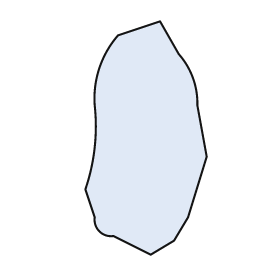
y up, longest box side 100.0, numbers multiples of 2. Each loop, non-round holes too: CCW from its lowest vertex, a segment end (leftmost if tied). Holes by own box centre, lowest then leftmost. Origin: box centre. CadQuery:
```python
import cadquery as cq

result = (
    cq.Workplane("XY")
    .moveTo(2.0, -50.0)
    .lineTo(12.0, -44.0)
    .lineTo(18.0, -34.0)
    .lineTo(26.0, -8.0)
    .lineTo(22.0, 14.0)
    .threePointArc((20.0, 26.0), (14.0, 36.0))
    .lineTo(6.0, 50.0)
    .lineTo(-12.0, 44.0)
    .threePointArc((-20.0, 30.0), (-22.0, 14.0))
    .threePointArc((-22.0, -4.0), (-26.0, -22.0))
    .lineTo(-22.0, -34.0)
    .threePointArc((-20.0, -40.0), (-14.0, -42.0))
    .close()
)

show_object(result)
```